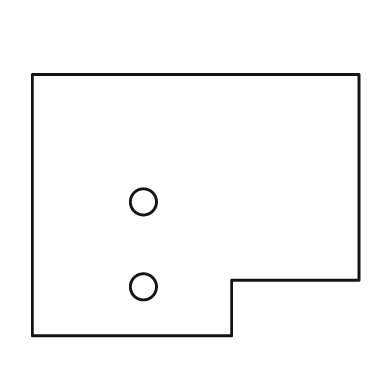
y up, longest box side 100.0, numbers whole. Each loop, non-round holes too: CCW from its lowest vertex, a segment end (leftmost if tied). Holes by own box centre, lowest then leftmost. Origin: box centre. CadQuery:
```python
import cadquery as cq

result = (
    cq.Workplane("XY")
    .moveTo(-50.0, -40.0)
    .lineTo(11.0, -40.0)
    .lineTo(11.0, -23.0)
    .lineTo(50.0, -23.0)
    .lineTo(50.0, 40.0)
    .lineTo(-50.0, 40.0)
    .close()
    .moveTo(-16.0, -25.0)
    .circle(4.0)
    .moveTo(-16.0, 1.0)
    .circle(4.0)
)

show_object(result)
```